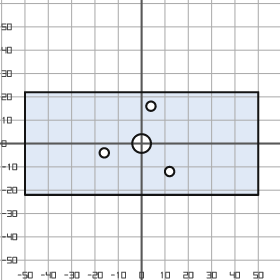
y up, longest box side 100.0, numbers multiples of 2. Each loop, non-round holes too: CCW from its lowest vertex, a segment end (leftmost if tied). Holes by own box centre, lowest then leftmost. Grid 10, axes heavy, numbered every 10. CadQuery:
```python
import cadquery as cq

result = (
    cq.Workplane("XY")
    .moveTo(-50.0, -22.0)
    .lineTo(50.0, -22.0)
    .lineTo(50.0, 22.0)
    .lineTo(-50.0, 22.0)
    .close()
    .moveTo(12.0, -12.0)
    .circle(2.0)
    .moveTo(-16.0, -4.0)
    .circle(2.0)
    .moveTo(0.0, 0.0)
    .circle(4.0)
    .moveTo(4.0, 16.0)
    .circle(2.0)
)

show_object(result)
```